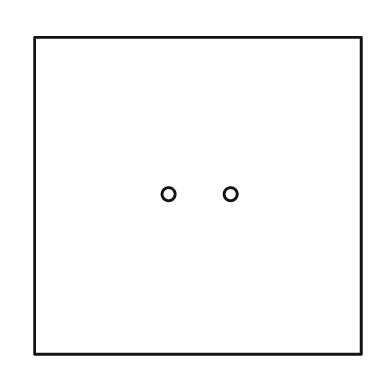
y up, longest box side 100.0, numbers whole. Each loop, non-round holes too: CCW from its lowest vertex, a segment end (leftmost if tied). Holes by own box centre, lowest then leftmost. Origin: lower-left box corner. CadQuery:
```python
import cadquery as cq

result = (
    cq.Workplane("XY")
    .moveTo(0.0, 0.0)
    .lineTo(100.0, 0.0)
    .lineTo(100.0, 97.0)
    .lineTo(0.0, 97.0)
    .close()
    .moveTo(41.0, 49.0)
    .circle(2.0)
    .moveTo(60.0, 49.0)
    .circle(2.0)
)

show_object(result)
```